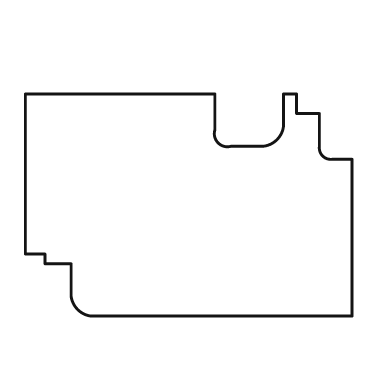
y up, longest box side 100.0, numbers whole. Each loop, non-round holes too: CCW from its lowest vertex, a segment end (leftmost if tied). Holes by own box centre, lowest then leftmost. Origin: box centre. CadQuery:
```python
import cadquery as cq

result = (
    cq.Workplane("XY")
    .moveTo(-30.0, -34.0)
    .lineTo(50.0, -34.0)
    .lineTo(50.0, 14.0)
    .lineTo(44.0, 14.0)
    .threePointArc((41.0, 15.0), (40.0, 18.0))
    .lineTo(40.0, 28.0)
    .lineTo(33.0, 28.0)
    .lineTo(33.0, 34.0)
    .lineTo(29.0, 34.0)
    .lineTo(29.0, 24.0)
    .threePointArc((27.0, 20.0), (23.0, 18.0))
    .lineTo(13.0, 18.0)
    .threePointArc((9.0, 19.0), (8.0, 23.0))
    .lineTo(8.0, 34.0)
    .lineTo(-50.0, 34.0)
    .lineTo(-50.0, -15.0)
    .lineTo(-44.0, -15.0)
    .lineTo(-44.0, -18.0)
    .lineTo(-36.0, -18.0)
    .lineTo(-36.0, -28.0)
    .threePointArc((-34.0, -32.0), (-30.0, -34.0))
    .close()
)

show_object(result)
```